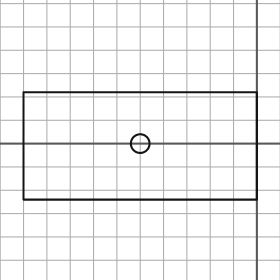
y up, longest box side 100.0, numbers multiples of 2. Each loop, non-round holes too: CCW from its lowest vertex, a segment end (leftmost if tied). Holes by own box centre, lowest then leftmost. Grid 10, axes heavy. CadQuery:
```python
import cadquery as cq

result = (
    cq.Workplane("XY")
    .moveTo(-100.0, -24.0)
    .lineTo(0.0, -24.0)
    .lineTo(0.0, 22.0)
    .lineTo(-100.0, 22.0)
    .close()
    .moveTo(-50.0, 0.0)
    .circle(4.0)
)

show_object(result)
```